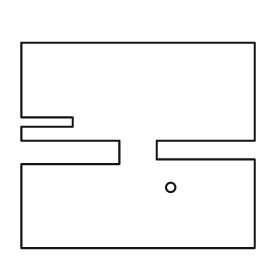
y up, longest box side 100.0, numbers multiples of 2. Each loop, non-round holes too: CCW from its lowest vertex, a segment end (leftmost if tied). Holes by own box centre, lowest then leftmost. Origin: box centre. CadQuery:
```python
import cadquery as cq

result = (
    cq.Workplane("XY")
    .moveTo(-50.0, -44.0)
    .lineTo(50.0, -44.0)
    .lineTo(50.0, -6.0)
    .lineTo(8.0, -6.0)
    .lineTo(8.0, 2.0)
    .lineTo(50.0, 2.0)
    .lineTo(50.0, 44.0)
    .lineTo(-50.0, 44.0)
    .lineTo(-50.0, 12.0)
    .lineTo(-28.0, 12.0)
    .lineTo(-28.0, 8.0)
    .lineTo(-50.0, 8.0)
    .lineTo(-50.0, 2.0)
    .lineTo(-8.0, 2.0)
    .lineTo(-8.0, -8.0)
    .lineTo(-50.0, -8.0)
    .close()
    .moveTo(14.0, -18.0)
    .circle(2.0)
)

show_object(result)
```